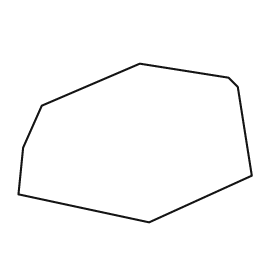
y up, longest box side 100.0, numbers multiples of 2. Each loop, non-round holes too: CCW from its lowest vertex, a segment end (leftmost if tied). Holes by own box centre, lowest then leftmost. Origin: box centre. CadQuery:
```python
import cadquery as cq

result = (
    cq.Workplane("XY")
    .moveTo(6.0, -34.0)
    .lineTo(50.0, -14.0)
    .lineTo(44.0, 24.0)
    .lineTo(40.0, 28.0)
    .lineTo(2.0, 34.0)
    .lineTo(-40.0, 16.0)
    .lineTo(-48.0, -2.0)
    .lineTo(-50.0, -22.0)
    .close()
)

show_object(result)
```